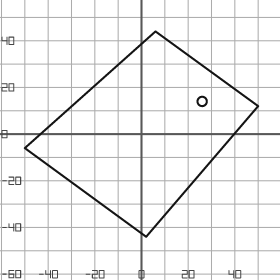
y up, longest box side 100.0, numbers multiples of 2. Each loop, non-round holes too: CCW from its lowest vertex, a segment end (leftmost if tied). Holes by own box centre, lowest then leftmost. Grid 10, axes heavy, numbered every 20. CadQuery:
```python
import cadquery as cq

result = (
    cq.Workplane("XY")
    .moveTo(2.0, -44.0)
    .lineTo(50.0, 12.0)
    .lineTo(6.0, 44.0)
    .lineTo(-50.0, -6.0)
    .close()
    .moveTo(26.0, 14.0)
    .circle(2.0)
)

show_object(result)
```